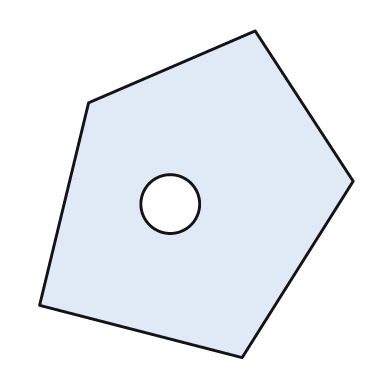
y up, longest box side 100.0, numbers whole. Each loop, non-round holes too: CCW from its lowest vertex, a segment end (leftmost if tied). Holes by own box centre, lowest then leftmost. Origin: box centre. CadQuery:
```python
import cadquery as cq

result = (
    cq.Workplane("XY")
    .moveTo(14.0, -50.0)
    .lineTo(48.0, 4.0)
    .lineTo(18.0, 50.0)
    .lineTo(-33.0, 28.0)
    .lineTo(-48.0, -34.0)
    .close()
    .moveTo(-8.0, -3.0)
    .circle(9.0)
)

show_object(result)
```